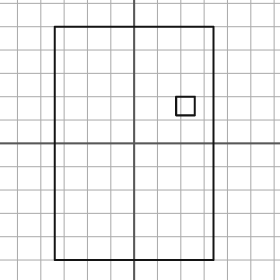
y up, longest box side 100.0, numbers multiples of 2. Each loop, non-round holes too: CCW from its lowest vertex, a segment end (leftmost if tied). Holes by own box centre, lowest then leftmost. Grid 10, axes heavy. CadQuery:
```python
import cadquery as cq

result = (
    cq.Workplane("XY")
    .moveTo(-34.0, -50.0)
    .lineTo(34.0, -50.0)
    .lineTo(34.0, 50.0)
    .lineTo(-34.0, 50.0)
    .close()
    .moveTo(18.0, 12.0)
    .lineTo(26.0, 12.0)
    .lineTo(26.0, 20.0)
    .lineTo(18.0, 20.0)
    .close()
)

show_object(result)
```